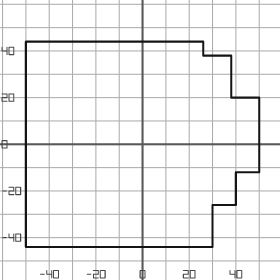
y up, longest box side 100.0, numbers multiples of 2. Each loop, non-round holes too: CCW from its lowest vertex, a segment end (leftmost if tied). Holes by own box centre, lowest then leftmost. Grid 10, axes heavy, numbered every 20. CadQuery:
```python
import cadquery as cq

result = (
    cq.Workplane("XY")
    .moveTo(-50.0, -44.0)
    .lineTo(30.0, -44.0)
    .lineTo(30.0, -26.0)
    .lineTo(40.0, -26.0)
    .lineTo(40.0, -12.0)
    .lineTo(50.0, -12.0)
    .lineTo(50.0, 20.0)
    .lineTo(38.0, 20.0)
    .lineTo(38.0, 38.0)
    .lineTo(26.0, 38.0)
    .lineTo(26.0, 44.0)
    .lineTo(-50.0, 44.0)
    .close()
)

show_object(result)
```